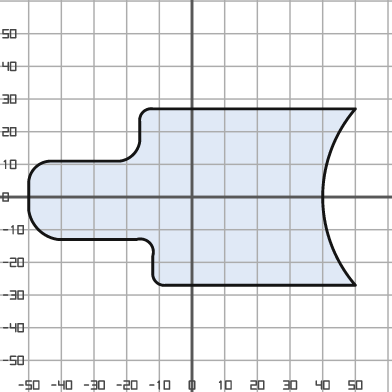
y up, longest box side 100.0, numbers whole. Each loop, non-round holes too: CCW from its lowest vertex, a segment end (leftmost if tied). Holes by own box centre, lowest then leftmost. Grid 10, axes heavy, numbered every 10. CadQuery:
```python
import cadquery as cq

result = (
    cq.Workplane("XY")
    .moveTo(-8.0, -27.0)
    .lineTo(50.0, -27.0)
    .threePointArc((40.0, 0.0), (50.0, 27.0))
    .lineTo(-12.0, 27.0)
    .threePointArc((-15.0, 26.0), (-16.0, 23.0))
    .lineTo(-16.0, 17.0)
    .threePointArc((-18.0, 13.0), (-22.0, 11.0))
    .lineTo(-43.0, 11.0)
    .threePointArc((-48.0, 9.0), (-50.0, 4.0))
    .lineTo(-50.0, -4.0)
    .threePointArc((-47.0, -10.0), (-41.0, -13.0))
    .lineTo(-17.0, -13.0)
    .threePointArc((-13.0, -14.0), (-12.0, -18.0))
    .lineTo(-12.0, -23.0)
    .threePointArc((-11.0, -26.0), (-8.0, -27.0))
    .close()
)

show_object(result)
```